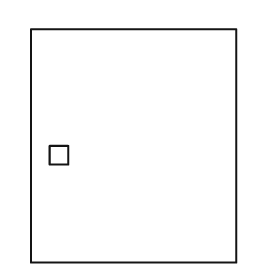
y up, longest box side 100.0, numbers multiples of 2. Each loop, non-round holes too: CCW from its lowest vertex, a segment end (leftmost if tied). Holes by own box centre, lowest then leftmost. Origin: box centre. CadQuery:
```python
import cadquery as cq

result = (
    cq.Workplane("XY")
    .moveTo(-44.0, -50.0)
    .lineTo(44.0, -50.0)
    .lineTo(44.0, 50.0)
    .lineTo(-44.0, 50.0)
    .close()
    .moveTo(-36.0, -8.0)
    .lineTo(-28.0, -8.0)
    .lineTo(-28.0, 0.0)
    .lineTo(-36.0, 0.0)
    .close()
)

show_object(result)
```